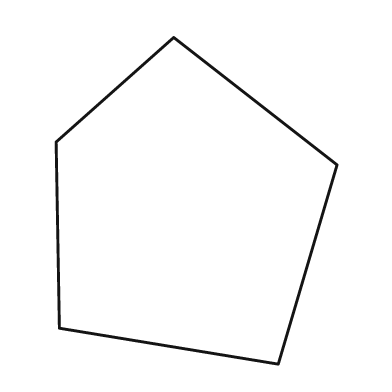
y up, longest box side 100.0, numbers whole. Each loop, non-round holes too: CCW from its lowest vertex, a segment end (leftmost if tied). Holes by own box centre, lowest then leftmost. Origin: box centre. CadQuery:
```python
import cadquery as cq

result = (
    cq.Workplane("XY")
    .moveTo(25.0, -50.0)
    .lineTo(43.0, 11.0)
    .lineTo(-7.0, 50.0)
    .lineTo(-43.0, 18.0)
    .lineTo(-42.0, -39.0)
    .close()
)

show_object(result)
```